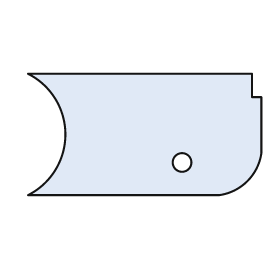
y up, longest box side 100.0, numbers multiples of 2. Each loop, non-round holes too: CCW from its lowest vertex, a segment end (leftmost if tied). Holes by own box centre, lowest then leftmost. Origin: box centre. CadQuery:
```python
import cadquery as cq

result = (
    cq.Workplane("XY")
    .moveTo(-50.0, -26.0)
    .lineTo(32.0, -26.0)
    .threePointArc((44.0, -20.0), (50.0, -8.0))
    .lineTo(50.0, 16.0)
    .lineTo(46.0, 16.0)
    .lineTo(46.0, 26.0)
    .lineTo(-50.0, 26.0)
    .threePointArc((-34.0, 0.0), (-50.0, -26.0))
    .close()
    .moveTo(16.0, -12.0)
    .circle(4.0)
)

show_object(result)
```